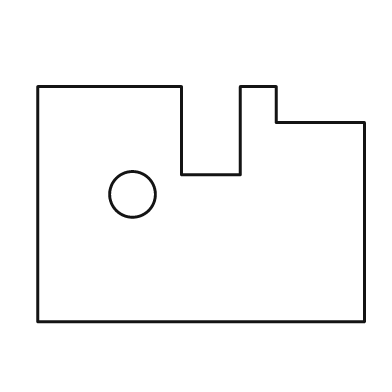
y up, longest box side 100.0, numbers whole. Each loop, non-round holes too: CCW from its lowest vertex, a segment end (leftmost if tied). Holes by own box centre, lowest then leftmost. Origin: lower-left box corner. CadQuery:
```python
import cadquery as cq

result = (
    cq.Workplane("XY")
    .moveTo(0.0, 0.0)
    .lineTo(100.0, 0.0)
    .lineTo(100.0, 61.0)
    .lineTo(73.0, 61.0)
    .lineTo(73.0, 72.0)
    .lineTo(62.0, 72.0)
    .lineTo(62.0, 45.0)
    .lineTo(44.0, 45.0)
    .lineTo(44.0, 72.0)
    .lineTo(0.0, 72.0)
    .close()
    .moveTo(29.0, 39.0)
    .circle(7.0)
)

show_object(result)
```